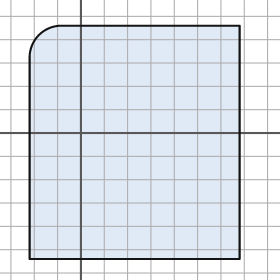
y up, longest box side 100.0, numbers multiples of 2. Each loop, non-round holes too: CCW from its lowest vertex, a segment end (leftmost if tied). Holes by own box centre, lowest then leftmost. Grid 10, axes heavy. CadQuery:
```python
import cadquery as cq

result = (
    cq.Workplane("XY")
    .moveTo(-22.0, -54.0)
    .lineTo(68.0, -54.0)
    .lineTo(68.0, 46.0)
    .lineTo(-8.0, 46.0)
    .threePointArc((-18.0, 42.0), (-22.0, 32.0))
    .close()
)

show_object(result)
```